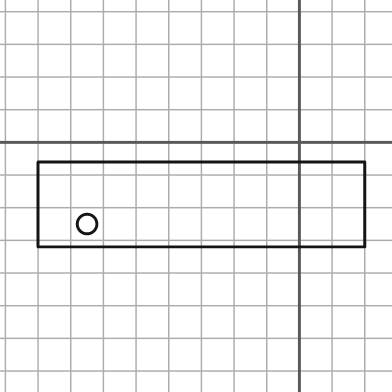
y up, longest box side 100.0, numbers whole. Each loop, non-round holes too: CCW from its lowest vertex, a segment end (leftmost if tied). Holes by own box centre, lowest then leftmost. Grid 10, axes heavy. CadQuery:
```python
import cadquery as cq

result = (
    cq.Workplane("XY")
    .moveTo(-80.0, -32.0)
    .lineTo(20.0, -32.0)
    .lineTo(20.0, -6.0)
    .lineTo(-80.0, -6.0)
    .close()
    .moveTo(-65.0, -25.0)
    .circle(3.0)
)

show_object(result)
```